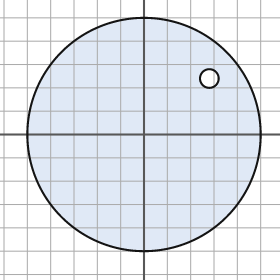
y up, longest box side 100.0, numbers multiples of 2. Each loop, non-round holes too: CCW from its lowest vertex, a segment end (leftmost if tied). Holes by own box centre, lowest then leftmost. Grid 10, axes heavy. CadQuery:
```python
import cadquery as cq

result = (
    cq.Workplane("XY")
    .moveTo(0.0, 0.0)
    .circle(50.0)
    .moveTo(28.0, 24.0)
    .circle(4.0)
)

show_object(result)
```